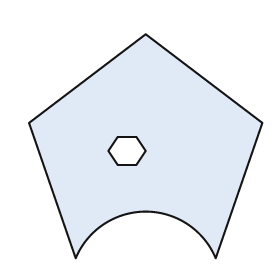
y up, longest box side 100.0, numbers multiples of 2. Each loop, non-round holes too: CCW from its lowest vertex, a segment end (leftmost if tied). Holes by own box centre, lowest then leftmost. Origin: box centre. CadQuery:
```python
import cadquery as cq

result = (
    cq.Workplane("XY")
    .moveTo(-30.0, -48.0)
    .threePointArc((0.0, -28.0), (30.0, -48.0))
    .lineTo(50.0, 10.0)
    .lineTo(0.0, 48.0)
    .lineTo(-50.0, 10.0)
    .close()
    .moveTo(-12.0, -8.0)
    .lineTo(-4.0, -8.0)
    .lineTo(0.0, -2.0)
    .lineTo(-4.0, 4.0)
    .lineTo(-12.0, 4.0)
    .lineTo(-16.0, -2.0)
    .close()
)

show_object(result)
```